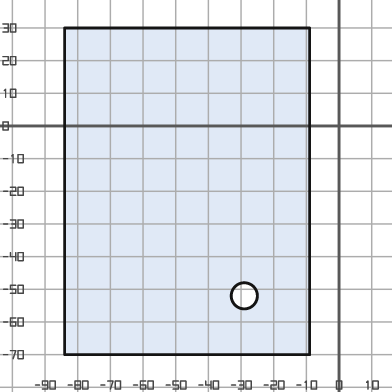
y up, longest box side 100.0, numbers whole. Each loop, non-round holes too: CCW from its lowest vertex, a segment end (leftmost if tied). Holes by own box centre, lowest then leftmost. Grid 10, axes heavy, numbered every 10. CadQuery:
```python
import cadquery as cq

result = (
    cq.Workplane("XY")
    .moveTo(-84.0, -70.0)
    .lineTo(-9.0, -70.0)
    .lineTo(-9.0, 30.0)
    .lineTo(-84.0, 30.0)
    .close()
    .moveTo(-29.0, -52.0)
    .circle(4.0)
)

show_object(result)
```